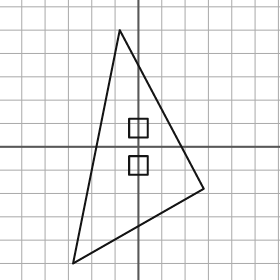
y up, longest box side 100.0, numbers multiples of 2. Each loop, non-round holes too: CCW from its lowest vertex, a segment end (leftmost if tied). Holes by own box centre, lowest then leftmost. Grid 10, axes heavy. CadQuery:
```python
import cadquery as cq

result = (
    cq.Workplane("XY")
    .moveTo(-28.0, -50.0)
    .lineTo(28.0, -18.0)
    .lineTo(-8.0, 50.0)
    .close()
    .moveTo(-4.0, -12.0)
    .lineTo(4.0, -12.0)
    .lineTo(4.0, -4.0)
    .lineTo(-4.0, -4.0)
    .close()
    .moveTo(-4.0, 4.0)
    .lineTo(4.0, 4.0)
    .lineTo(4.0, 12.0)
    .lineTo(-4.0, 12.0)
    .close()
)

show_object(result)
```